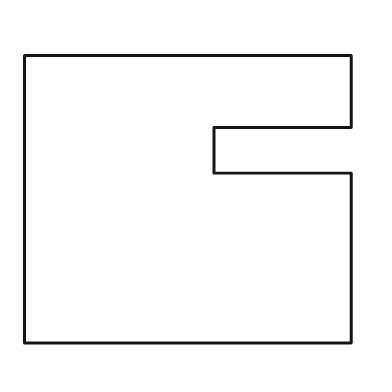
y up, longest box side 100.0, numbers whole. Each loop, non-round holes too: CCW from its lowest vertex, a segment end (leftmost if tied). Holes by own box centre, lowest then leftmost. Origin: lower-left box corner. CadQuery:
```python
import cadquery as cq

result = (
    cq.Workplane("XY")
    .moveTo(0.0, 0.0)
    .lineTo(100.0, 0.0)
    .lineTo(100.0, 52.0)
    .lineTo(58.0, 52.0)
    .lineTo(58.0, 66.0)
    .lineTo(100.0, 66.0)
    .lineTo(100.0, 88.0)
    .lineTo(0.0, 88.0)
    .close()
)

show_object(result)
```